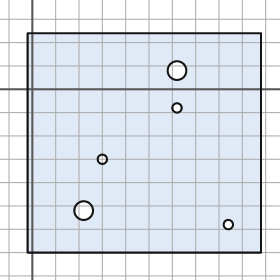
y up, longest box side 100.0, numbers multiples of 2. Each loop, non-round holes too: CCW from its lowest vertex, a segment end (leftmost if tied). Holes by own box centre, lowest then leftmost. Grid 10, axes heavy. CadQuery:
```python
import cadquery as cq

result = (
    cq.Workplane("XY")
    .moveTo(-2.0, -70.0)
    .lineTo(98.0, -70.0)
    .lineTo(98.0, 24.0)
    .lineTo(-2.0, 24.0)
    .close()
    .moveTo(84.0, -58.0)
    .circle(2.0)
    .moveTo(22.0, -52.0)
    .circle(4.0)
    .moveTo(30.0, -30.0)
    .circle(2.0)
    .moveTo(62.0, -8.0)
    .circle(2.0)
    .moveTo(62.0, 8.0)
    .circle(4.0)
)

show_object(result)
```